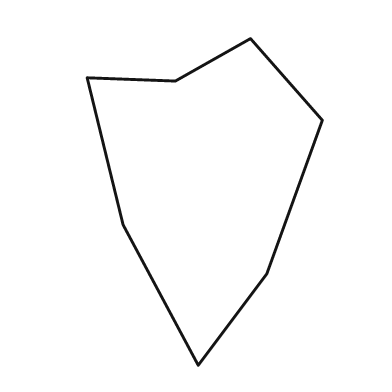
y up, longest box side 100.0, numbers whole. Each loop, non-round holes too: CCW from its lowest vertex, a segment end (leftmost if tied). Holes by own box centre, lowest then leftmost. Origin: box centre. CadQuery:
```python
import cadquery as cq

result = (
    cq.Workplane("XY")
    .moveTo(-2.0, -50.0)
    .lineTo(19.0, -22.0)
    .lineTo(36.0, 25.0)
    .lineTo(14.0, 50.0)
    .lineTo(-9.0, 37.0)
    .lineTo(-36.0, 38.0)
    .lineTo(-25.0, -7.0)
    .close()
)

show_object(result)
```